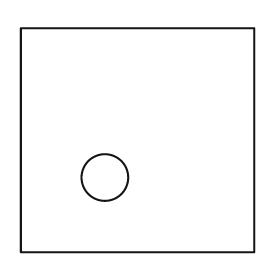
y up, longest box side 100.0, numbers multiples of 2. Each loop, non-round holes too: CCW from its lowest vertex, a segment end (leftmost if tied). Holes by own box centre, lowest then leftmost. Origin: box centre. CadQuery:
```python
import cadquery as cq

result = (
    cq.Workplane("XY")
    .moveTo(-50.0, -48.0)
    .lineTo(50.0, -48.0)
    .lineTo(50.0, 48.0)
    .lineTo(-50.0, 48.0)
    .close()
    .moveTo(-14.0, -16.0)
    .circle(10.0)
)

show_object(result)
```